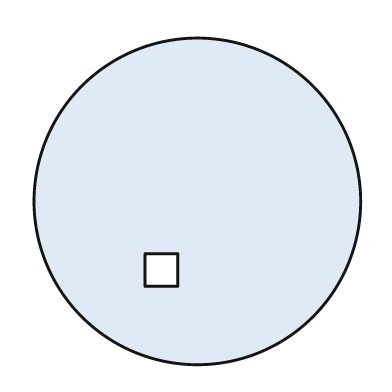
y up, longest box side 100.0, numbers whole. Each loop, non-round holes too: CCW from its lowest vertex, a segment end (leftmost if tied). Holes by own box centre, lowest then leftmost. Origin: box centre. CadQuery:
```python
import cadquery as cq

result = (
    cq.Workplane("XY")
    .moveTo(0.0, 0.0)
    .circle(50.0)
    .moveTo(-16.0, -26.0)
    .lineTo(-6.0, -26.0)
    .lineTo(-6.0, -16.0)
    .lineTo(-16.0, -16.0)
    .close()
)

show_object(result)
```